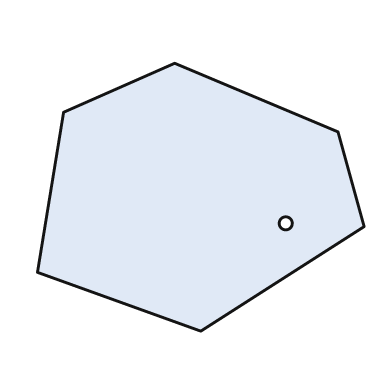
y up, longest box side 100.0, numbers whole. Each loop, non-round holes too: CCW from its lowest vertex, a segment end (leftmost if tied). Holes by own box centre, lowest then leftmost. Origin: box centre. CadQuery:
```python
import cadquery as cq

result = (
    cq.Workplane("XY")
    .moveTo(0.0, -41.0)
    .lineTo(50.0, -9.0)
    .lineTo(42.0, 20.0)
    .lineTo(-8.0, 41.0)
    .lineTo(-42.0, 26.0)
    .lineTo(-50.0, -23.0)
    .close()
    .moveTo(26.0, -8.0)
    .circle(2.0)
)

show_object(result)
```